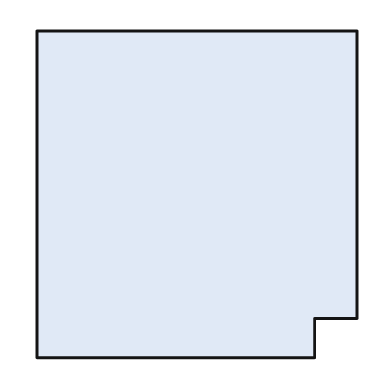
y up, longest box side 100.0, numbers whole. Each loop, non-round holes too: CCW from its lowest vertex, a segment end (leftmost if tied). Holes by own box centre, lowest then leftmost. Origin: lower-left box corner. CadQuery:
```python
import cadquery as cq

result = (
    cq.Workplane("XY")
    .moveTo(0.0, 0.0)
    .lineTo(85.0, 0.0)
    .lineTo(85.0, 12.0)
    .lineTo(98.0, 12.0)
    .lineTo(98.0, 100.0)
    .lineTo(0.0, 100.0)
    .close()
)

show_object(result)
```